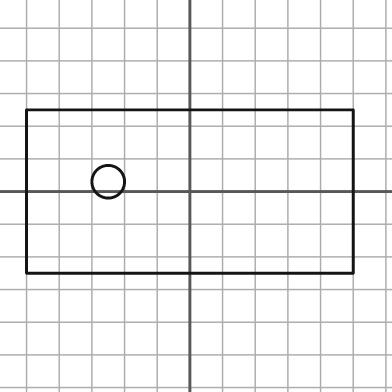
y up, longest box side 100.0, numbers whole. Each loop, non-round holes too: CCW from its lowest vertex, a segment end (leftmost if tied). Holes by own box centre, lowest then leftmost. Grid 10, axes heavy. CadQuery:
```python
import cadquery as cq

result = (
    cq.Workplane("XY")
    .moveTo(-50.0, -25.0)
    .lineTo(50.0, -25.0)
    .lineTo(50.0, 25.0)
    .lineTo(-50.0, 25.0)
    .close()
    .moveTo(-25.0, 3.0)
    .circle(5.0)
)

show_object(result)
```